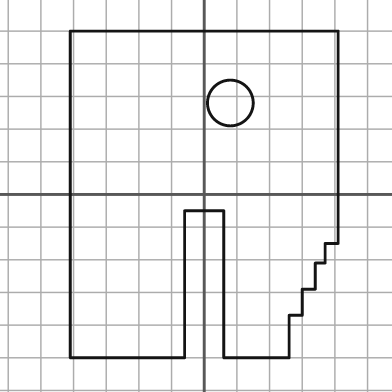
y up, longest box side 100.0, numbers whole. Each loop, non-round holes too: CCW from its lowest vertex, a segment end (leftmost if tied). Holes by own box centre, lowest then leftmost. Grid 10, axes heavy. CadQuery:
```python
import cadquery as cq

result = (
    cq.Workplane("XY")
    .moveTo(-41.0, -50.0)
    .lineTo(-6.0, -50.0)
    .lineTo(-6.0, -5.0)
    .lineTo(6.0, -5.0)
    .lineTo(6.0, -50.0)
    .lineTo(26.0, -50.0)
    .lineTo(26.0, -37.0)
    .lineTo(30.0, -37.0)
    .lineTo(30.0, -29.0)
    .lineTo(34.0, -29.0)
    .lineTo(34.0, -21.0)
    .lineTo(37.0, -21.0)
    .lineTo(37.0, -15.0)
    .lineTo(41.0, -15.0)
    .lineTo(41.0, 50.0)
    .lineTo(-41.0, 50.0)
    .close()
    .moveTo(8.0, 28.0)
    .circle(7.0)
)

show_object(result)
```